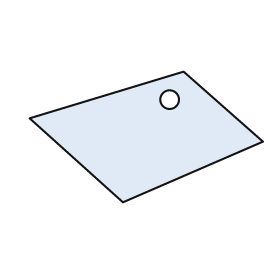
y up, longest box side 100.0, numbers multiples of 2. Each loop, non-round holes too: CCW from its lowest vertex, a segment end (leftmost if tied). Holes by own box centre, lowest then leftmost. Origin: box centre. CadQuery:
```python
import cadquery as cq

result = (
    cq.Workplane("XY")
    .moveTo(-10.0, -28.0)
    .lineTo(50.0, -2.0)
    .lineTo(16.0, 28.0)
    .lineTo(-50.0, 8.0)
    .close()
    .moveTo(10.0, 16.0)
    .circle(4.0)
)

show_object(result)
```